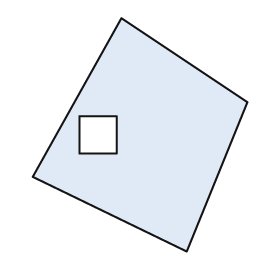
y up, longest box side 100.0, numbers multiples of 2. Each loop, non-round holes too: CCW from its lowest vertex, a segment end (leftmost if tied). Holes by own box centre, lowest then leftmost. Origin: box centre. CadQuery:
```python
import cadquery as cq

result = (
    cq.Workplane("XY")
    .moveTo(20.0, -50.0)
    .lineTo(46.0, 14.0)
    .lineTo(-8.0, 50.0)
    .lineTo(-46.0, -18.0)
    .close()
    .moveTo(-26.0, -8.0)
    .lineTo(-10.0, -8.0)
    .lineTo(-10.0, 8.0)
    .lineTo(-26.0, 8.0)
    .close()
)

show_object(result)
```